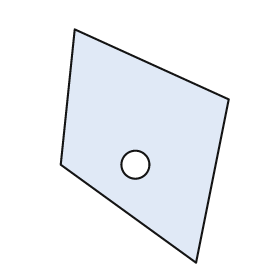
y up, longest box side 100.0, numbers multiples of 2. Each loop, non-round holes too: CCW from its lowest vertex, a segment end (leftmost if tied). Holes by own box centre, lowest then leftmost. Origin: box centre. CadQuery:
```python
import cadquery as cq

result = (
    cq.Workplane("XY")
    .moveTo(22.0, -50.0)
    .lineTo(36.0, 20.0)
    .lineTo(-30.0, 50.0)
    .lineTo(-36.0, -8.0)
    .close()
    .moveTo(-4.0, -8.0)
    .circle(6.0)
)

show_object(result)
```